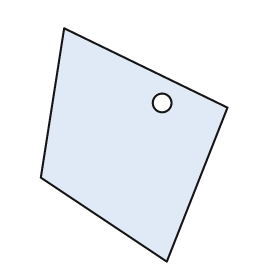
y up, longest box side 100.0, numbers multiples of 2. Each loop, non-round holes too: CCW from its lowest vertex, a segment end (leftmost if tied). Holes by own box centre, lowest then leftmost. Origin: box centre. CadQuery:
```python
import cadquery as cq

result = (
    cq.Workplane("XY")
    .moveTo(14.0, -50.0)
    .lineTo(40.0, 16.0)
    .lineTo(-30.0, 50.0)
    .lineTo(-40.0, -14.0)
    .close()
    .moveTo(12.0, 18.0)
    .circle(4.0)
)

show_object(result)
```